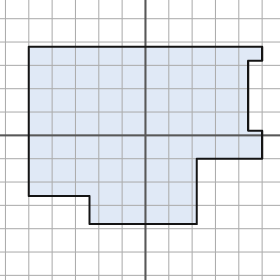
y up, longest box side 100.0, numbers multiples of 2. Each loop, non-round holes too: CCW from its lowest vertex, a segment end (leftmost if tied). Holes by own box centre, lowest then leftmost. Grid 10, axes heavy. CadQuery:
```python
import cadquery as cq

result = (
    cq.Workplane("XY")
    .moveTo(-24.0, -38.0)
    .lineTo(22.0, -38.0)
    .lineTo(22.0, -10.0)
    .lineTo(50.0, -10.0)
    .lineTo(50.0, 2.0)
    .lineTo(44.0, 2.0)
    .lineTo(44.0, 32.0)
    .lineTo(50.0, 32.0)
    .lineTo(50.0, 38.0)
    .lineTo(-50.0, 38.0)
    .lineTo(-50.0, -26.0)
    .lineTo(-24.0, -26.0)
    .close()
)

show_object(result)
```